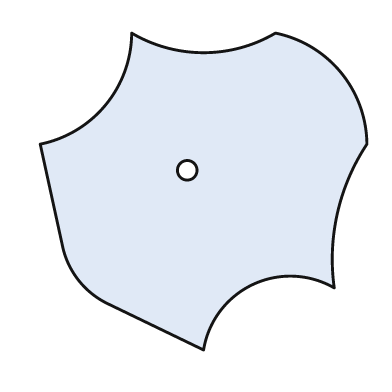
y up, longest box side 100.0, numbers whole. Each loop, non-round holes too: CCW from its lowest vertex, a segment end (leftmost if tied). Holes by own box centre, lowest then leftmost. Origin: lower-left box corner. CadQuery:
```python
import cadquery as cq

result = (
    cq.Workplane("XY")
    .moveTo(50.0, 0.0)
    .threePointArc((65.0, 20.0), (90.0, 19.0))
    .threePointArc((91.0, 42.0), (100.0, 63.0))
    .threePointArc((92.0, 85.0), (72.0, 97.0))
    .threePointArc((50.0, 91.0), (28.0, 97.0))
    .threePointArc((20.0, 75.0), (0.0, 63.0))
    .lineTo(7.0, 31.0)
    .threePointArc((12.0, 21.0), (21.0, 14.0))
    .close()
    .moveTo(45.0, 55.0)
    .circle(3.0)
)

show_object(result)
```